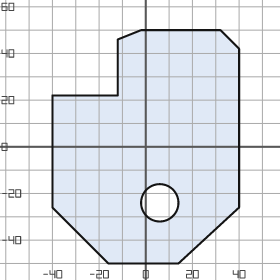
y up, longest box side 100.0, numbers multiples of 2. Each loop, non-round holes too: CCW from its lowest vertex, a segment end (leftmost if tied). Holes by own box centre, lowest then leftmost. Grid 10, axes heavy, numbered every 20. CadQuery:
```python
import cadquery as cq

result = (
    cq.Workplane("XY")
    .moveTo(-16.0, -50.0)
    .lineTo(14.0, -50.0)
    .lineTo(40.0, -26.0)
    .lineTo(40.0, 42.0)
    .lineTo(32.0, 50.0)
    .lineTo(-2.0, 50.0)
    .lineTo(-12.0, 46.0)
    .lineTo(-12.0, 22.0)
    .lineTo(-40.0, 22.0)
    .lineTo(-40.0, -26.0)
    .close()
    .moveTo(6.0, -24.0)
    .circle(8.0)
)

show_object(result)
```